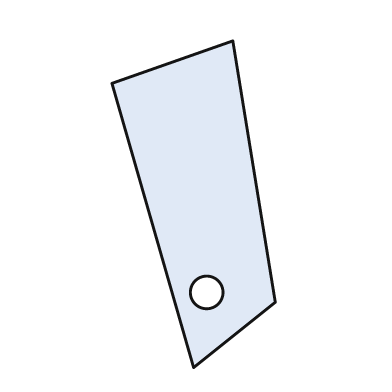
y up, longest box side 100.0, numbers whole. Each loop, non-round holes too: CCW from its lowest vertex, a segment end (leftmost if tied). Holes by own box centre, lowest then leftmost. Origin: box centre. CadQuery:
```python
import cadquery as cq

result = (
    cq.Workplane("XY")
    .moveTo(0.0, -50.0)
    .lineTo(25.0, -30.0)
    .lineTo(12.0, 50.0)
    .lineTo(-25.0, 37.0)
    .close()
    .moveTo(4.0, -27.0)
    .circle(5.0)
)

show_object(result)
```